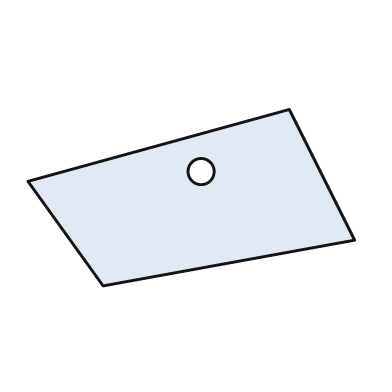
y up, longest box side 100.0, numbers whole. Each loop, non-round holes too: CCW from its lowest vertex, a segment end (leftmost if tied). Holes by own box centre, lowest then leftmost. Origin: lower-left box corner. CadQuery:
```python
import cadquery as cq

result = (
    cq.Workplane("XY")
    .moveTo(23.0, 0.0)
    .lineTo(100.0, 14.0)
    .lineTo(80.0, 54.0)
    .lineTo(0.0, 32.0)
    .close()
    .moveTo(53.0, 35.0)
    .circle(4.0)
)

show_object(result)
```